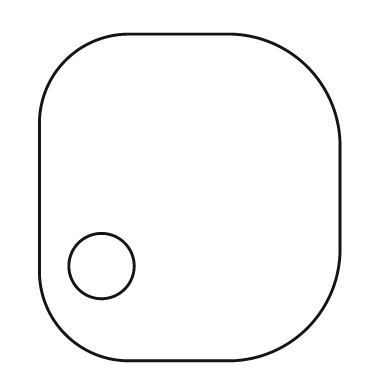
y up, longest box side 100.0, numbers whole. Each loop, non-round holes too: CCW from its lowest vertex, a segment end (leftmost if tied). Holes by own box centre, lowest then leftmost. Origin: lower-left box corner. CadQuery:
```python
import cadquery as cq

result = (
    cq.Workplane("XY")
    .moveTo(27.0, 0.0)
    .lineTo(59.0, 0.0)
    .threePointArc((82.0, 10.0), (92.0, 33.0))
    .lineTo(92.0, 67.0)
    .threePointArc((82.0, 90.0), (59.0, 100.0))
    .lineTo(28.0, 100.0)
    .threePointArc((8.0, 92.0), (0.0, 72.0))
    .lineTo(0.0, 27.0)
    .threePointArc((8.0, 8.0), (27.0, 0.0))
    .close()
    .moveTo(19.0, 29.0)
    .circle(10.0)
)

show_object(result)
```